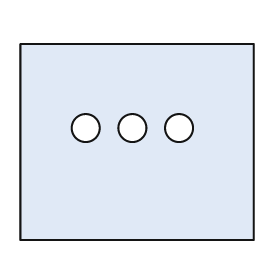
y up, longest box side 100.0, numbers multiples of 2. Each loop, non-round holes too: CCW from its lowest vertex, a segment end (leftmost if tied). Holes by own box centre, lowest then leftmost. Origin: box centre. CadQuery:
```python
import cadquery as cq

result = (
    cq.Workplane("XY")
    .moveTo(-50.0, -42.0)
    .lineTo(50.0, -42.0)
    .lineTo(50.0, 42.0)
    .lineTo(-50.0, 42.0)
    .close()
    .moveTo(-22.0, 6.0)
    .circle(6.0)
    .moveTo(-2.0, 6.0)
    .circle(6.0)
    .moveTo(18.0, 6.0)
    .circle(6.0)
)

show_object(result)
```